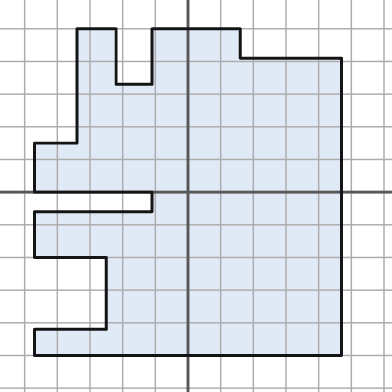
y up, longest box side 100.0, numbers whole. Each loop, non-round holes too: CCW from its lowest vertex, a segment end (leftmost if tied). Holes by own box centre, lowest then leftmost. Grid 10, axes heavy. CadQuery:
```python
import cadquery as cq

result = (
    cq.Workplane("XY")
    .moveTo(-47.0, -50.0)
    .lineTo(47.0, -50.0)
    .lineTo(47.0, 41.0)
    .lineTo(16.0, 41.0)
    .lineTo(16.0, 50.0)
    .lineTo(-11.0, 50.0)
    .lineTo(-11.0, 33.0)
    .lineTo(-22.0, 33.0)
    .lineTo(-22.0, 50.0)
    .lineTo(-34.0, 50.0)
    .lineTo(-34.0, 15.0)
    .lineTo(-47.0, 15.0)
    .lineTo(-47.0, 0.0)
    .lineTo(-11.0, 0.0)
    .lineTo(-11.0, -6.0)
    .lineTo(-47.0, -6.0)
    .lineTo(-47.0, -20.0)
    .lineTo(-25.0, -20.0)
    .lineTo(-25.0, -42.0)
    .lineTo(-47.0, -42.0)
    .close()
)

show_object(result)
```